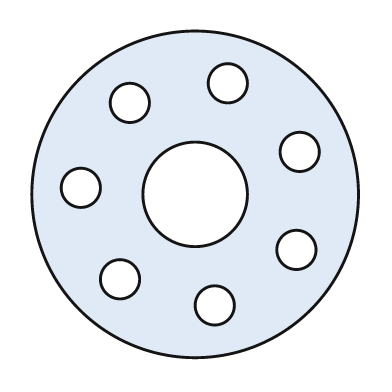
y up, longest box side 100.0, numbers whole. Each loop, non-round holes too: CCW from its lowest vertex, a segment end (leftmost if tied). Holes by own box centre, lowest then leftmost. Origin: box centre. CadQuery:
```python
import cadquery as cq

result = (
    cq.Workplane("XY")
    .moveTo(0.0, 0.0)
    .circle(50.0)
    .moveTo(6.0, -34.0)
    .circle(6.0)
    .moveTo(-23.0, -26.0)
    .circle(6.0)
    .moveTo(31.0, -17.0)
    .circle(6.0)
    .moveTo(0.0, 0.0)
    .circle(16.0)
    .moveTo(-35.0, 2.0)
    .circle(6.0)
    .moveTo(32.0, 13.0)
    .circle(6.0)
    .moveTo(-20.0, 28.0)
    .circle(6.0)
    .moveTo(10.0, 34.0)
    .circle(6.0)
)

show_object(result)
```